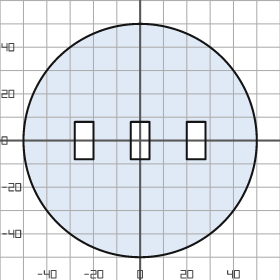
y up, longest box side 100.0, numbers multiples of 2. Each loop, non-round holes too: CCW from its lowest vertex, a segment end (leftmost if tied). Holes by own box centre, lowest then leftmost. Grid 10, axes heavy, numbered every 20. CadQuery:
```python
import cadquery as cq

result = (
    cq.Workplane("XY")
    .moveTo(0.0, 0.0)
    .circle(50.0)
    .moveTo(-28.0, -8.0)
    .lineTo(-20.0, -8.0)
    .lineTo(-20.0, 8.0)
    .lineTo(-28.0, 8.0)
    .close()
    .moveTo(-4.0, -8.0)
    .lineTo(4.0, -8.0)
    .lineTo(4.0, 8.0)
    .lineTo(-4.0, 8.0)
    .close()
    .moveTo(20.0, -8.0)
    .lineTo(28.0, -8.0)
    .lineTo(28.0, 8.0)
    .lineTo(20.0, 8.0)
    .close()
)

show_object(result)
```